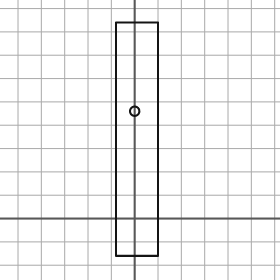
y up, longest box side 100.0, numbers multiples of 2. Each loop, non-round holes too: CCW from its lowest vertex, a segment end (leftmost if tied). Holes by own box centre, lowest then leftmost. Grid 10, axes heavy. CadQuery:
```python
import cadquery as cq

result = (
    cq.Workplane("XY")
    .moveTo(-8.0, -16.0)
    .lineTo(10.0, -16.0)
    .lineTo(10.0, 84.0)
    .lineTo(-8.0, 84.0)
    .close()
    .moveTo(0.0, 46.0)
    .circle(2.0)
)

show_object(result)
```